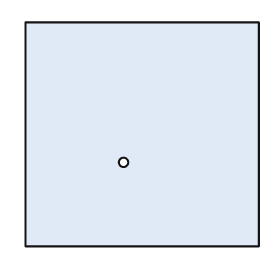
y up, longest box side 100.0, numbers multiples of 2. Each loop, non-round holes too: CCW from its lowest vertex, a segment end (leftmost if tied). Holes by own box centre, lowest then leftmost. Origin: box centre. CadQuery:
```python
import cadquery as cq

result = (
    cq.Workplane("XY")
    .moveTo(-50.0, -48.0)
    .lineTo(50.0, -48.0)
    .lineTo(50.0, 48.0)
    .lineTo(-50.0, 48.0)
    .close()
    .moveTo(-8.0, -12.0)
    .circle(2.0)
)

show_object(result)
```